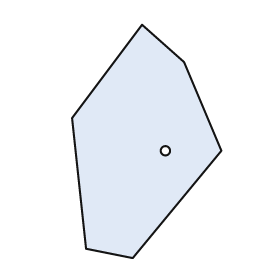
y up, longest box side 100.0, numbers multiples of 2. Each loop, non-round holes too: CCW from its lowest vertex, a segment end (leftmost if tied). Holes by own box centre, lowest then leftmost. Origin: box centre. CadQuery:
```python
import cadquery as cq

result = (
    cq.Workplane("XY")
    .moveTo(-6.0, -50.0)
    .lineTo(32.0, -4.0)
    .lineTo(16.0, 34.0)
    .lineTo(-2.0, 50.0)
    .lineTo(-32.0, 10.0)
    .lineTo(-26.0, -46.0)
    .close()
    .moveTo(8.0, -4.0)
    .circle(2.0)
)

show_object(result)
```